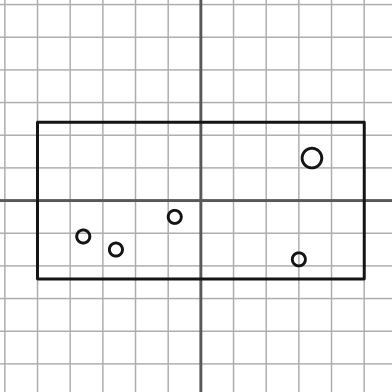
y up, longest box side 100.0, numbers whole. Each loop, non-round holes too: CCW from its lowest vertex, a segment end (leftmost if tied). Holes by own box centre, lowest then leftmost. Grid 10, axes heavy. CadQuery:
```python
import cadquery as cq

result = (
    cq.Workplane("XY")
    .moveTo(-50.0, -24.0)
    .lineTo(50.0, -24.0)
    .lineTo(50.0, 24.0)
    .lineTo(-50.0, 24.0)
    .close()
    .moveTo(30.0, -18.0)
    .circle(2.0)
    .moveTo(-26.0, -15.0)
    .circle(2.0)
    .moveTo(-36.0, -11.0)
    .circle(2.0)
    .moveTo(-8.0, -5.0)
    .circle(2.0)
    .moveTo(34.0, 13.0)
    .circle(3.0)
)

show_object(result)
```